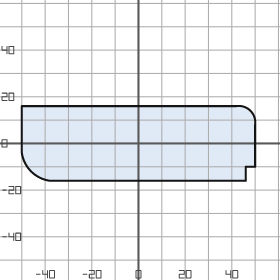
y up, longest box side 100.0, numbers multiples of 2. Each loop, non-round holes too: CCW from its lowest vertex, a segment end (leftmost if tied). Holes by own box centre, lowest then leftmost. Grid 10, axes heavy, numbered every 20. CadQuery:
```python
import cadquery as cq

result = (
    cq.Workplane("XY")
    .moveTo(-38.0, -16.0)
    .lineTo(46.0, -16.0)
    .lineTo(46.0, -10.0)
    .lineTo(50.0, -10.0)
    .lineTo(50.0, 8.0)
    .threePointArc((48.0, 14.0), (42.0, 16.0))
    .lineTo(-50.0, 16.0)
    .lineTo(-50.0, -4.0)
    .threePointArc((-46.0, -12.0), (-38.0, -16.0))
    .close()
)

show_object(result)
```